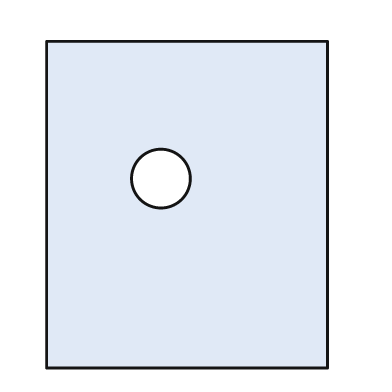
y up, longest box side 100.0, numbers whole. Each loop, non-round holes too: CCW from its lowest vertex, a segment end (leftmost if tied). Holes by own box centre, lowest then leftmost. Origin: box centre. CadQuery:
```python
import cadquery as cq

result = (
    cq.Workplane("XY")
    .moveTo(-43.0, -50.0)
    .lineTo(43.0, -50.0)
    .lineTo(43.0, 50.0)
    .lineTo(-43.0, 50.0)
    .close()
    .moveTo(-8.0, 8.0)
    .circle(9.0)
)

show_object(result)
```